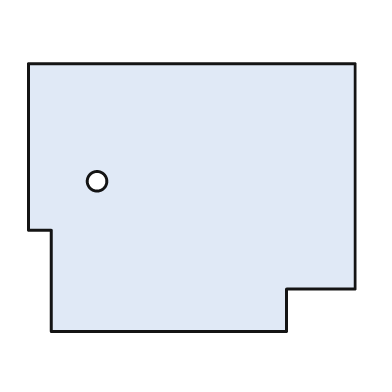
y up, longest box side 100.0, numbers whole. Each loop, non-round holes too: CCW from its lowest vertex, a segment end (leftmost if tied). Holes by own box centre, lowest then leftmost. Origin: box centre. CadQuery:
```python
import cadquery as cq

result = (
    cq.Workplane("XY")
    .moveTo(-43.0, -41.0)
    .lineTo(29.0, -41.0)
    .lineTo(29.0, -28.0)
    .lineTo(50.0, -28.0)
    .lineTo(50.0, 41.0)
    .lineTo(-50.0, 41.0)
    .lineTo(-50.0, -10.0)
    .lineTo(-43.0, -10.0)
    .close()
    .moveTo(-29.0, 5.0)
    .circle(3.0)
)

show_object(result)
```